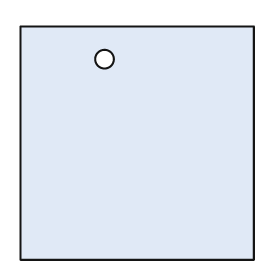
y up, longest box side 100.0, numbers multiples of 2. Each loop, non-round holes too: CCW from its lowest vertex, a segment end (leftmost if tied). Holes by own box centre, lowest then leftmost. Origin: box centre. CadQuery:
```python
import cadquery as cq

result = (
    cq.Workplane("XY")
    .moveTo(-50.0, -50.0)
    .lineTo(50.0, -50.0)
    .lineTo(50.0, 50.0)
    .lineTo(-50.0, 50.0)
    .close()
    .moveTo(-14.0, 36.0)
    .circle(4.0)
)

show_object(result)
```